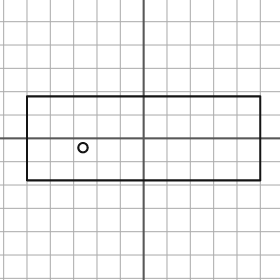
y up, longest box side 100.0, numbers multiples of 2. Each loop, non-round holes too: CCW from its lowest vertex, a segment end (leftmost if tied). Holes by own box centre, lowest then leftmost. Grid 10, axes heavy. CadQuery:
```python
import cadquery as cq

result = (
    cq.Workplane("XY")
    .moveTo(-50.0, -18.0)
    .lineTo(50.0, -18.0)
    .lineTo(50.0, 18.0)
    .lineTo(-50.0, 18.0)
    .close()
    .moveTo(-26.0, -4.0)
    .circle(2.0)
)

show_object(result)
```